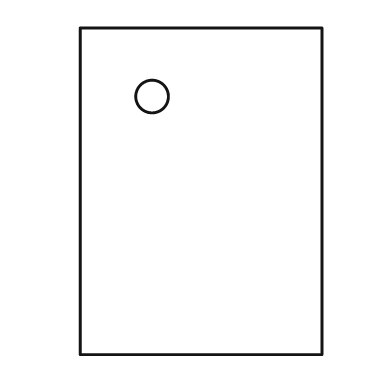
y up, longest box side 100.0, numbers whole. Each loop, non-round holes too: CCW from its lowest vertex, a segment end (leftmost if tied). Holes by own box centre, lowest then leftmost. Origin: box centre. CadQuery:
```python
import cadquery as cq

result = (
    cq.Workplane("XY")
    .moveTo(-37.0, -50.0)
    .lineTo(37.0, -50.0)
    .lineTo(37.0, 50.0)
    .lineTo(-37.0, 50.0)
    .close()
    .moveTo(-15.0, 29.0)
    .circle(5.0)
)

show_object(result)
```